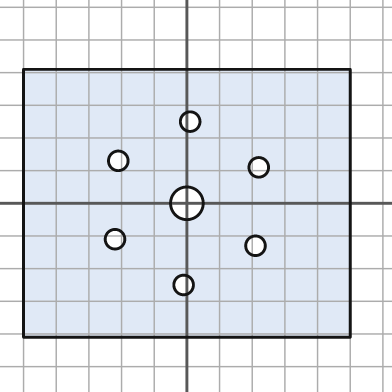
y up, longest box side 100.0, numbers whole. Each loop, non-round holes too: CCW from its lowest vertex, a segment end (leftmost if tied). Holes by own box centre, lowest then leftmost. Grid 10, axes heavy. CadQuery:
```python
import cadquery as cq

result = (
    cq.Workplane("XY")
    .moveTo(-50.0, -41.0)
    .lineTo(50.0, -41.0)
    .lineTo(50.0, 41.0)
    .lineTo(-50.0, 41.0)
    .close()
    .moveTo(-1.0, -25.0)
    .circle(3.0)
    .moveTo(21.0, -13.0)
    .circle(3.0)
    .moveTo(-22.0, -11.0)
    .circle(3.0)
    .moveTo(0.0, 0.0)
    .circle(5.0)
    .moveTo(22.0, 11.0)
    .circle(3.0)
    .moveTo(-21.0, 13.0)
    .circle(3.0)
    .moveTo(1.0, 25.0)
    .circle(3.0)
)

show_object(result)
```